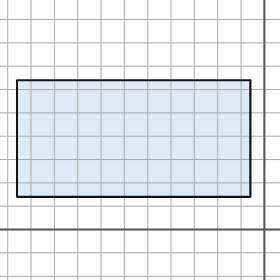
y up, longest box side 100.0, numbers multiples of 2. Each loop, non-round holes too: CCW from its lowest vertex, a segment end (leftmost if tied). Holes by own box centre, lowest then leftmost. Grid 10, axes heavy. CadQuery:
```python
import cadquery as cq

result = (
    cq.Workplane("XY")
    .moveTo(-106.0, 14.0)
    .lineTo(-6.0, 14.0)
    .lineTo(-6.0, 64.0)
    .lineTo(-106.0, 64.0)
    .close()
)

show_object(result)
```